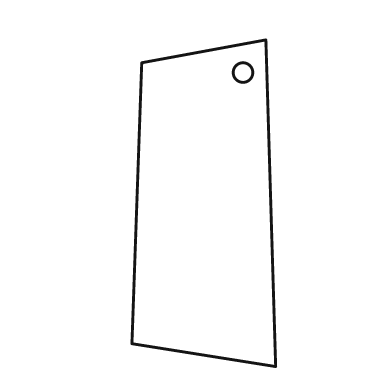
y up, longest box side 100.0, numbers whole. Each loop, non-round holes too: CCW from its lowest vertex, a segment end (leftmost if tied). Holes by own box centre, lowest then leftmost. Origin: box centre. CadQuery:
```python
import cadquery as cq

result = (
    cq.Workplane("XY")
    .moveTo(22.0, -50.0)
    .lineTo(19.0, 50.0)
    .lineTo(-19.0, 43.0)
    .lineTo(-22.0, -43.0)
    .close()
    .moveTo(12.0, 40.0)
    .circle(3.0)
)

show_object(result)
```